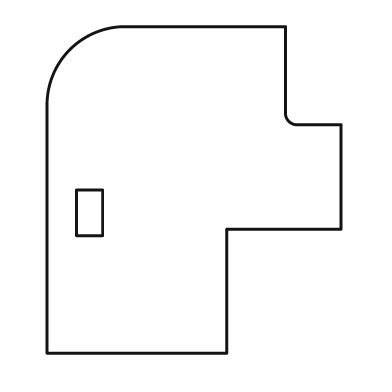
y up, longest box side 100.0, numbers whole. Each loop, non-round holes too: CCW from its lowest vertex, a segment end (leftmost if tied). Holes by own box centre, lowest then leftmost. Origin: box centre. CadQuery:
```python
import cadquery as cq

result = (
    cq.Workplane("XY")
    .moveTo(-45.0, -50.0)
    .lineTo(10.0, -50.0)
    .lineTo(10.0, -12.0)
    .lineTo(45.0, -12.0)
    .lineTo(45.0, 20.0)
    .lineTo(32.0, 20.0)
    .threePointArc((29.0, 21.0), (28.0, 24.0))
    .lineTo(28.0, 50.0)
    .lineTo(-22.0, 50.0)
    .threePointArc((-38.0, 43.0), (-45.0, 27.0))
    .close()
    .moveTo(-36.0, -14.0)
    .lineTo(-28.0, -14.0)
    .lineTo(-28.0, 0.0)
    .lineTo(-36.0, 0.0)
    .close()
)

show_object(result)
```